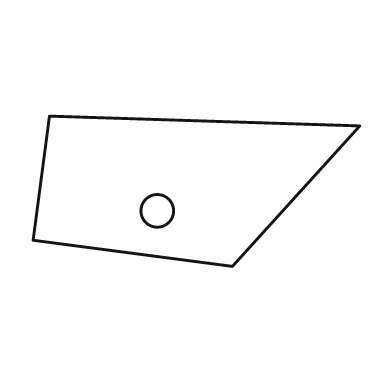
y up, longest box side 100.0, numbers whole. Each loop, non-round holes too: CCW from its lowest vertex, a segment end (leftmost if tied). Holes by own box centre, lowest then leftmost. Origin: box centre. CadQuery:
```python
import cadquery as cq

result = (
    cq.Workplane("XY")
    .moveTo(11.0, -23.0)
    .lineTo(50.0, 20.0)
    .lineTo(-45.0, 23.0)
    .lineTo(-50.0, -15.0)
    .close()
    .moveTo(-12.0, -6.0)
    .circle(5.0)
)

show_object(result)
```